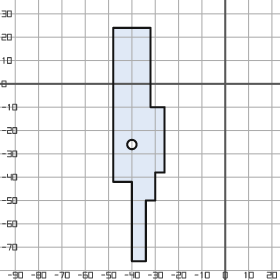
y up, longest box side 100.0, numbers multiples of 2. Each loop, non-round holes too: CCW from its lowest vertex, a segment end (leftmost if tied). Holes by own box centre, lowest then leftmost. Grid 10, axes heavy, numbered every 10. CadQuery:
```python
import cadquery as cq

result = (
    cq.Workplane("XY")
    .moveTo(-40.0, -76.0)
    .lineTo(-34.0, -76.0)
    .lineTo(-34.0, -50.0)
    .lineTo(-30.0, -50.0)
    .lineTo(-30.0, -38.0)
    .lineTo(-26.0, -38.0)
    .lineTo(-26.0, -10.0)
    .lineTo(-32.0, -10.0)
    .lineTo(-32.0, 24.0)
    .lineTo(-48.0, 24.0)
    .lineTo(-48.0, -42.0)
    .lineTo(-40.0, -42.0)
    .close()
    .moveTo(-40.0, -26.0)
    .circle(2.0)
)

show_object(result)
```